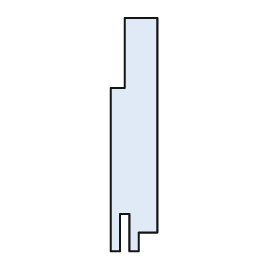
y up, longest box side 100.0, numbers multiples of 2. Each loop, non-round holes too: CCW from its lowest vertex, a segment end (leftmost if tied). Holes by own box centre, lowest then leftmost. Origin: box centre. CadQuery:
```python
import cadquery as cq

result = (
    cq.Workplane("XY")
    .moveTo(-10.0, -50.0)
    .lineTo(-6.0, -50.0)
    .lineTo(-6.0, -34.0)
    .lineTo(-2.0, -34.0)
    .lineTo(-2.0, -50.0)
    .lineTo(2.0, -50.0)
    .lineTo(2.0, -42.0)
    .lineTo(10.0, -42.0)
    .lineTo(10.0, 50.0)
    .lineTo(-4.0, 50.0)
    .lineTo(-4.0, 20.0)
    .lineTo(-10.0, 20.0)
    .close()
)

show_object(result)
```